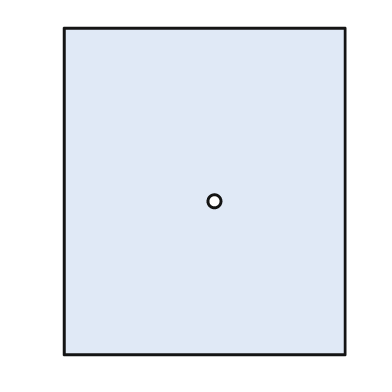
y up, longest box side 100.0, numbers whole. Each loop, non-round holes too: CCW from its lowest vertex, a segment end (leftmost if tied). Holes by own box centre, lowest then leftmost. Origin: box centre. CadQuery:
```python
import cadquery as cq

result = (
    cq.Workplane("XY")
    .moveTo(-43.0, -50.0)
    .lineTo(43.0, -50.0)
    .lineTo(43.0, 50.0)
    .lineTo(-43.0, 50.0)
    .close()
    .moveTo(3.0, -3.0)
    .circle(2.0)
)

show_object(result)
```